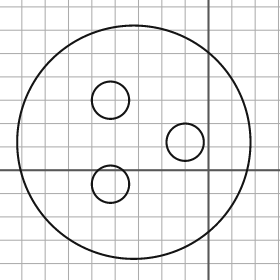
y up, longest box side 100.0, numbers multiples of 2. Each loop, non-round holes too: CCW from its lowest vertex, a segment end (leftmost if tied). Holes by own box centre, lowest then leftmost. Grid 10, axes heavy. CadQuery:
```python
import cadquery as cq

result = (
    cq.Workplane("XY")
    .moveTo(-32.0, 12.0)
    .circle(50.0)
    .moveTo(-42.0, -6.0)
    .circle(8.0)
    .moveTo(-10.0, 12.0)
    .circle(8.0)
    .moveTo(-42.0, 30.0)
    .circle(8.0)
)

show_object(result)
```